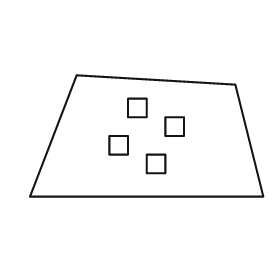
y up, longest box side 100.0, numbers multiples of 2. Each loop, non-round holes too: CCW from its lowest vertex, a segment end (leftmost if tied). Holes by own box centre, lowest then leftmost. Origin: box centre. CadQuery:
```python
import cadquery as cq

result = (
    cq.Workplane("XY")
    .moveTo(-50.0, -26.0)
    .lineTo(50.0, -26.0)
    .lineTo(38.0, 22.0)
    .lineTo(-30.0, 26.0)
    .close()
    .moveTo(0.0, -16.0)
    .lineTo(8.0, -16.0)
    .lineTo(8.0, -8.0)
    .lineTo(0.0, -8.0)
    .close()
    .moveTo(-16.0, -8.0)
    .lineTo(-8.0, -8.0)
    .lineTo(-8.0, 0.0)
    .lineTo(-16.0, 0.0)
    .close()
    .moveTo(8.0, 0.0)
    .lineTo(16.0, 0.0)
    .lineTo(16.0, 8.0)
    .lineTo(8.0, 8.0)
    .close()
    .moveTo(-8.0, 8.0)
    .lineTo(0.0, 8.0)
    .lineTo(0.0, 16.0)
    .lineTo(-8.0, 16.0)
    .close()
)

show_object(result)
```